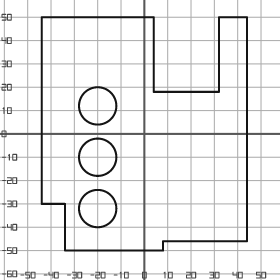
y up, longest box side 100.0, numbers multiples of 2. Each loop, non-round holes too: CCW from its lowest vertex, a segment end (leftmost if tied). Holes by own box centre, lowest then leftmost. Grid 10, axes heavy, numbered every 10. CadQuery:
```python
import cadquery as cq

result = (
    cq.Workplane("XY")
    .moveTo(-34.0, -50.0)
    .lineTo(8.0, -50.0)
    .lineTo(8.0, -46.0)
    .lineTo(44.0, -46.0)
    .lineTo(44.0, 50.0)
    .lineTo(32.0, 50.0)
    .lineTo(32.0, 18.0)
    .lineTo(4.0, 18.0)
    .lineTo(4.0, 50.0)
    .lineTo(-44.0, 50.0)
    .lineTo(-44.0, -30.0)
    .lineTo(-34.0, -30.0)
    .close()
    .moveTo(-20.0, -32.0)
    .circle(8.0)
    .moveTo(-20.0, -10.0)
    .circle(8.0)
    .moveTo(-20.0, 12.0)
    .circle(8.0)
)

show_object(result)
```